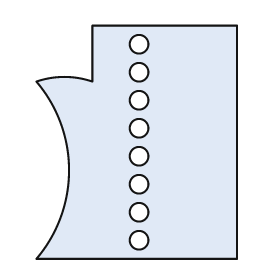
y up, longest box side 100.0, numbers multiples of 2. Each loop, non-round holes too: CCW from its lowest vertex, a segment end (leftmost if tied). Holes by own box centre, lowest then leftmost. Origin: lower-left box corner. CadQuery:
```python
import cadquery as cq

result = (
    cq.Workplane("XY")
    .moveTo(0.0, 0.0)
    .lineTo(86.0, 0.0)
    .lineTo(86.0, 100.0)
    .lineTo(24.0, 100.0)
    .lineTo(24.0, 76.0)
    .threePointArc((12.0, 78.0), (0.0, 76.0))
    .threePointArc((14.0, 38.0), (0.0, 0.0))
    .close()
    .moveTo(44.0, 8.0)
    .circle(4.0)
    .moveTo(44.0, 20.0)
    .circle(4.0)
    .moveTo(44.0, 32.0)
    .circle(4.0)
    .moveTo(44.0, 44.0)
    .circle(4.0)
    .moveTo(44.0, 56.0)
    .circle(4.0)
    .moveTo(44.0, 68.0)
    .circle(4.0)
    .moveTo(44.0, 80.0)
    .circle(4.0)
    .moveTo(44.0, 92.0)
    .circle(4.0)
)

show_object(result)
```